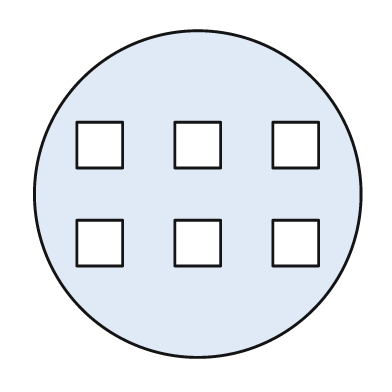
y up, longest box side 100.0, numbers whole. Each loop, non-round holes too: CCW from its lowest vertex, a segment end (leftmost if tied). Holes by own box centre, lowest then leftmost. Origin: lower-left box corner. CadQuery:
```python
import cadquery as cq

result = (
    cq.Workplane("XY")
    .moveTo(50.0, 50.0)
    .circle(50.0)
    .moveTo(13.0, 28.0)
    .lineTo(27.0, 28.0)
    .lineTo(27.0, 42.0)
    .lineTo(13.0, 42.0)
    .close()
    .moveTo(43.0, 28.0)
    .lineTo(57.0, 28.0)
    .lineTo(57.0, 42.0)
    .lineTo(43.0, 42.0)
    .close()
    .moveTo(73.0, 28.0)
    .lineTo(87.0, 28.0)
    .lineTo(87.0, 42.0)
    .lineTo(73.0, 42.0)
    .close()
    .moveTo(13.0, 58.0)
    .lineTo(27.0, 58.0)
    .lineTo(27.0, 72.0)
    .lineTo(13.0, 72.0)
    .close()
    .moveTo(43.0, 58.0)
    .lineTo(57.0, 58.0)
    .lineTo(57.0, 72.0)
    .lineTo(43.0, 72.0)
    .close()
    .moveTo(73.0, 58.0)
    .lineTo(87.0, 58.0)
    .lineTo(87.0, 72.0)
    .lineTo(73.0, 72.0)
    .close()
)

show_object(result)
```